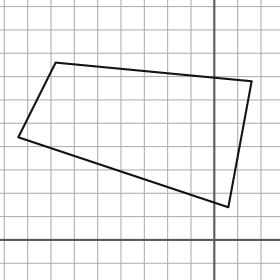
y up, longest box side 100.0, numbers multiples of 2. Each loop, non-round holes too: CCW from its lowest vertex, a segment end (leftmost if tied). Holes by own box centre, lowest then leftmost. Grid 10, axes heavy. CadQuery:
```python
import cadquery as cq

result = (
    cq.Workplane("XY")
    .moveTo(6.0, 14.0)
    .lineTo(16.0, 68.0)
    .lineTo(-68.0, 76.0)
    .lineTo(-84.0, 44.0)
    .close()
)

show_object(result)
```